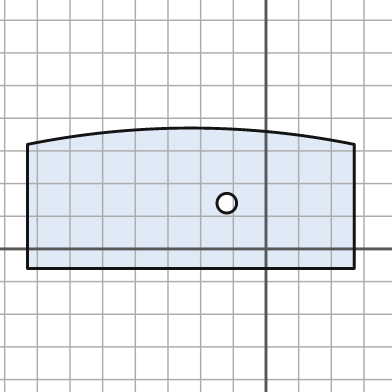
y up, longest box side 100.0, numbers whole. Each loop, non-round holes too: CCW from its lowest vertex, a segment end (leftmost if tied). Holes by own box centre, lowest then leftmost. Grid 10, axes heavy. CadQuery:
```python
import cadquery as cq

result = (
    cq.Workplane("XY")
    .moveTo(-73.0, -6.0)
    .lineTo(27.0, -6.0)
    .lineTo(27.0, 32.0)
    .threePointArc((-23.0, 37.0), (-73.0, 32.0))
    .close()
    .moveTo(-12.0, 14.0)
    .circle(3.0)
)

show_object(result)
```